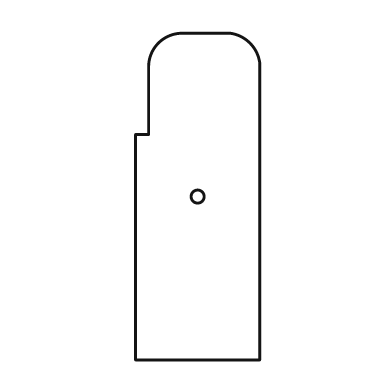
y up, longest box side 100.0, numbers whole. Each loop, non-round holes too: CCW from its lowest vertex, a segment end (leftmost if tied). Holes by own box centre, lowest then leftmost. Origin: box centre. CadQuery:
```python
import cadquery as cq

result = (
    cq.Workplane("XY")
    .moveTo(-19.0, -50.0)
    .lineTo(19.0, -50.0)
    .lineTo(19.0, 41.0)
    .threePointArc((16.0, 47.0), (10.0, 50.0))
    .lineTo(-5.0, 50.0)
    .threePointArc((-12.0, 47.0), (-15.0, 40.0))
    .lineTo(-15.0, 19.0)
    .lineTo(-19.0, 19.0)
    .close()
    .moveTo(0.0, 0.0)
    .circle(2.0)
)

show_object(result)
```